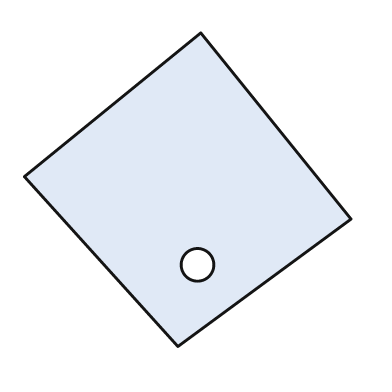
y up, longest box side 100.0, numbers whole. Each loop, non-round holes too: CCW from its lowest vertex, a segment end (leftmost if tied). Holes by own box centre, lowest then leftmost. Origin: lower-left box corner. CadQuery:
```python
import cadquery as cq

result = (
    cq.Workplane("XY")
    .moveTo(47.0, 0.0)
    .lineTo(100.0, 39.0)
    .lineTo(54.0, 96.0)
    .lineTo(0.0, 52.0)
    .close()
    .moveTo(53.0, 25.0)
    .circle(5.0)
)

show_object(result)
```